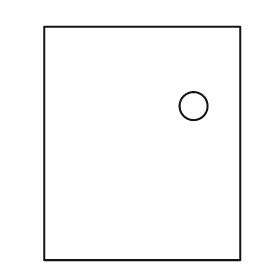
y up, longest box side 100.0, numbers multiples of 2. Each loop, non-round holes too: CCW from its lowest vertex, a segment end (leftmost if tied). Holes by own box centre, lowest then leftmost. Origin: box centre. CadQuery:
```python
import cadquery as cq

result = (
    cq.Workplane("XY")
    .moveTo(-42.0, -50.0)
    .lineTo(42.0, -50.0)
    .lineTo(42.0, 50.0)
    .lineTo(-42.0, 50.0)
    .close()
    .moveTo(22.0, 16.0)
    .circle(6.0)
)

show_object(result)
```